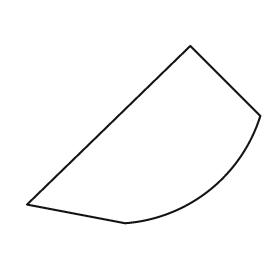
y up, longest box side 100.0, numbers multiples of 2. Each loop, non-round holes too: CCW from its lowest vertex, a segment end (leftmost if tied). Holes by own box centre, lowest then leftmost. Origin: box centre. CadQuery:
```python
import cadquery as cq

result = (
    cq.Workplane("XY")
    .moveTo(-8.0, -38.0)
    .threePointArc((28.0, -24.0), (50.0, 8.0))
    .lineTo(20.0, 38.0)
    .lineTo(-50.0, -30.0)
    .close()
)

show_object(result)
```